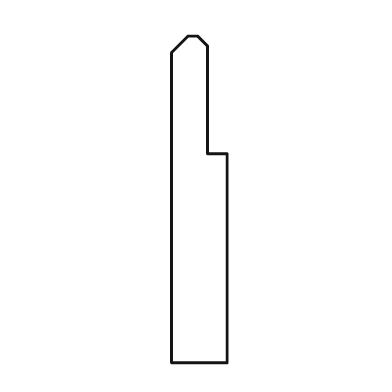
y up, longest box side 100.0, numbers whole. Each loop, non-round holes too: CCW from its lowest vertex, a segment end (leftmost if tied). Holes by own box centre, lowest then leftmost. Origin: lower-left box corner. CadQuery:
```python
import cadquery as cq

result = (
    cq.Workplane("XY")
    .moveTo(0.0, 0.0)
    .lineTo(17.0, 0.0)
    .lineTo(17.0, 64.0)
    .lineTo(11.0, 64.0)
    .lineTo(11.0, 97.0)
    .lineTo(8.0, 100.0)
    .lineTo(5.0, 100.0)
    .lineTo(0.0, 95.0)
    .close()
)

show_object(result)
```